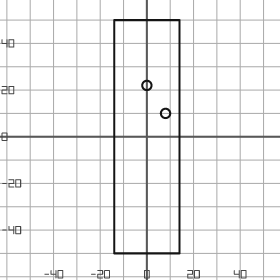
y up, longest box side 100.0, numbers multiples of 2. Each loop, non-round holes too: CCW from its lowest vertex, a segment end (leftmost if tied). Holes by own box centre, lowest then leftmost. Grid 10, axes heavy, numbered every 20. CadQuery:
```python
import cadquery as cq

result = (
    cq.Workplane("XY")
    .moveTo(-14.0, -50.0)
    .lineTo(14.0, -50.0)
    .lineTo(14.0, 50.0)
    .lineTo(-14.0, 50.0)
    .close()
    .moveTo(8.0, 10.0)
    .circle(2.0)
    .moveTo(0.0, 22.0)
    .circle(2.0)
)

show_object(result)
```